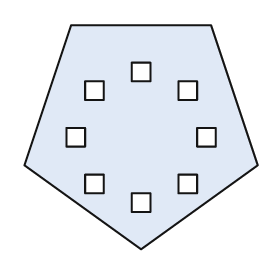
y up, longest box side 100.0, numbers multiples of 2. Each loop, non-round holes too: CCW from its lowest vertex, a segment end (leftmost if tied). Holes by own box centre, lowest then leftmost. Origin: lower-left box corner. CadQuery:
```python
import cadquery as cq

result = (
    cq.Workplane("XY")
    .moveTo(50.0, 0.0)
    .lineTo(100.0, 36.0)
    .lineTo(80.0, 96.0)
    .lineTo(20.0, 96.0)
    .lineTo(0.0, 36.0)
    .close()
    .moveTo(46.0, 16.0)
    .lineTo(54.0, 16.0)
    .lineTo(54.0, 24.0)
    .lineTo(46.0, 24.0)
    .close()
    .moveTo(26.0, 24.0)
    .lineTo(34.0, 24.0)
    .lineTo(34.0, 32.0)
    .lineTo(26.0, 32.0)
    .close()
    .moveTo(66.0, 24.0)
    .lineTo(74.0, 24.0)
    .lineTo(74.0, 32.0)
    .lineTo(66.0, 32.0)
    .close()
    .moveTo(18.0, 44.0)
    .lineTo(26.0, 44.0)
    .lineTo(26.0, 52.0)
    .lineTo(18.0, 52.0)
    .close()
    .moveTo(74.0, 44.0)
    .lineTo(82.0, 44.0)
    .lineTo(82.0, 52.0)
    .lineTo(74.0, 52.0)
    .close()
    .moveTo(26.0, 64.0)
    .lineTo(34.0, 64.0)
    .lineTo(34.0, 72.0)
    .lineTo(26.0, 72.0)
    .close()
    .moveTo(66.0, 64.0)
    .lineTo(74.0, 64.0)
    .lineTo(74.0, 72.0)
    .lineTo(66.0, 72.0)
    .close()
    .moveTo(46.0, 72.0)
    .lineTo(54.0, 72.0)
    .lineTo(54.0, 80.0)
    .lineTo(46.0, 80.0)
    .close()
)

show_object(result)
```